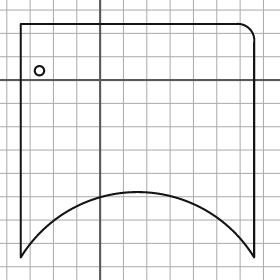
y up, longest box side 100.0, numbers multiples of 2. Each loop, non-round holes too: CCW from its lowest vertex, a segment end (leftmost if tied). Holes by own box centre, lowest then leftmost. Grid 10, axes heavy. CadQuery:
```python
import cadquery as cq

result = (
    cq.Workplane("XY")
    .moveTo(-34.0, -76.0)
    .threePointArc((16.0, -48.0), (66.0, -76.0))
    .lineTo(66.0, 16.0)
    .threePointArc((64.0, 22.0), (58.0, 24.0))
    .lineTo(-34.0, 24.0)
    .close()
    .moveTo(-26.0, 4.0)
    .circle(2.0)
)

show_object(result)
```